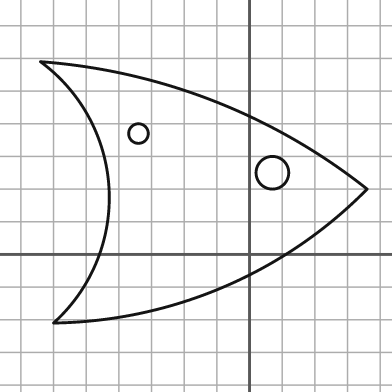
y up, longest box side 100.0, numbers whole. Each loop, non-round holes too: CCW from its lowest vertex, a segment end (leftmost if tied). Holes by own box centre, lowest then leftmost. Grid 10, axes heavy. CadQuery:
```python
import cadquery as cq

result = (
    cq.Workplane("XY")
    .moveTo(-60.0, -21.0)
    .threePointArc((-8.0, -10.0), (36.0, 20.0))
    .threePointArc((-11.0, 47.0), (-64.0, 59.0))
    .threePointArc((-43.0, 20.0), (-60.0, -21.0))
    .close()
    .moveTo(7.0, 25.0)
    .circle(5.0)
    .moveTo(-34.0, 37.0)
    .circle(3.0)
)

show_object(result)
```